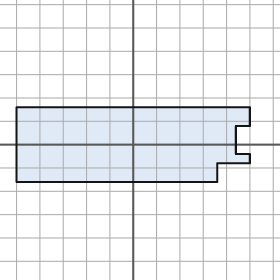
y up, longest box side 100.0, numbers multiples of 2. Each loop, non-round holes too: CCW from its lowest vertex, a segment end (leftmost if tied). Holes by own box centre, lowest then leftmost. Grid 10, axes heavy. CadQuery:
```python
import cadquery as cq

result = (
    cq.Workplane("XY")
    .moveTo(-50.0, -16.0)
    .lineTo(36.0, -16.0)
    .lineTo(36.0, -8.0)
    .lineTo(50.0, -8.0)
    .lineTo(50.0, -4.0)
    .lineTo(44.0, -4.0)
    .lineTo(44.0, 8.0)
    .lineTo(50.0, 8.0)
    .lineTo(50.0, 16.0)
    .lineTo(-50.0, 16.0)
    .close()
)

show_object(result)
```